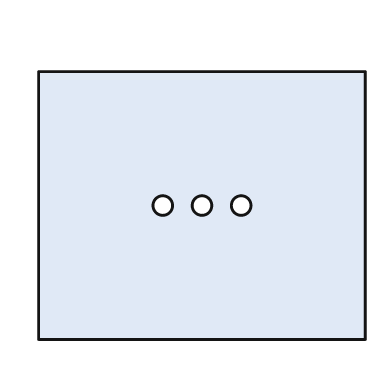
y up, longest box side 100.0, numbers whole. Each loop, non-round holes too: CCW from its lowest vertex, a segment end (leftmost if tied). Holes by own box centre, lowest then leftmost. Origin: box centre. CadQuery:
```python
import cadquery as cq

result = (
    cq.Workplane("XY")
    .moveTo(-50.0, -41.0)
    .lineTo(50.0, -41.0)
    .lineTo(50.0, 41.0)
    .lineTo(-50.0, 41.0)
    .close()
    .moveTo(-12.0, 0.0)
    .circle(3.0)
    .moveTo(0.0, 0.0)
    .circle(3.0)
    .moveTo(12.0, 0.0)
    .circle(3.0)
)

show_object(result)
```